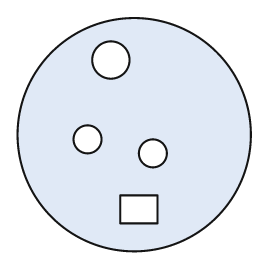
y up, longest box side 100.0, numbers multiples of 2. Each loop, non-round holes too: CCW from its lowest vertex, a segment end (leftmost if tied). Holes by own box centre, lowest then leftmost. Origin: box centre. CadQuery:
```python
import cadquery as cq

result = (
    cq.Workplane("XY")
    .moveTo(0.0, 0.0)
    .circle(50.0)
    .moveTo(-6.0, -38.0)
    .lineTo(10.0, -38.0)
    .lineTo(10.0, -26.0)
    .lineTo(-6.0, -26.0)
    .close()
    .moveTo(8.0, -8.0)
    .circle(6.0)
    .moveTo(-20.0, -2.0)
    .circle(6.0)
    .moveTo(-10.0, 32.0)
    .circle(8.0)
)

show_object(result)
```